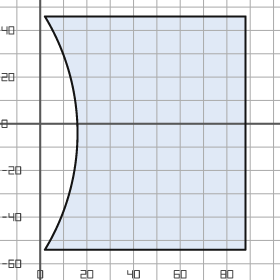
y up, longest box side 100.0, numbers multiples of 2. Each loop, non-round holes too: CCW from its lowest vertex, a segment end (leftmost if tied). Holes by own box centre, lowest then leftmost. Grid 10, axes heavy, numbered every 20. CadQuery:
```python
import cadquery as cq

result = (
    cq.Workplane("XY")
    .moveTo(2.0, -54.0)
    .lineTo(88.0, -54.0)
    .lineTo(88.0, 46.0)
    .lineTo(2.0, 46.0)
    .threePointArc((16.0, -4.0), (2.0, -54.0))
    .close()
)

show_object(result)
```